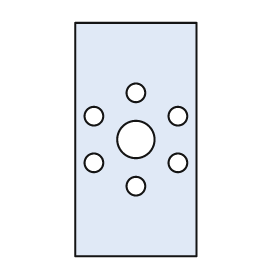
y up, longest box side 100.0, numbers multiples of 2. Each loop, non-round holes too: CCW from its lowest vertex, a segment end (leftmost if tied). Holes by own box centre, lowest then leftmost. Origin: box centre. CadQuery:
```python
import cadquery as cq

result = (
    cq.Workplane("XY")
    .moveTo(-26.0, -50.0)
    .lineTo(26.0, -50.0)
    .lineTo(26.0, 50.0)
    .lineTo(-26.0, 50.0)
    .close()
    .moveTo(0.0, -20.0)
    .circle(4.0)
    .moveTo(-18.0, -10.0)
    .circle(4.0)
    .moveTo(18.0, -10.0)
    .circle(4.0)
    .moveTo(0.0, 0.0)
    .circle(8.0)
    .moveTo(-18.0, 10.0)
    .circle(4.0)
    .moveTo(18.0, 10.0)
    .circle(4.0)
    .moveTo(0.0, 20.0)
    .circle(4.0)
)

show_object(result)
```